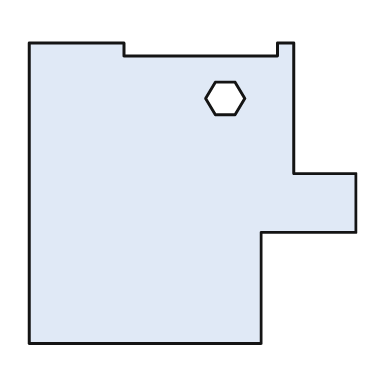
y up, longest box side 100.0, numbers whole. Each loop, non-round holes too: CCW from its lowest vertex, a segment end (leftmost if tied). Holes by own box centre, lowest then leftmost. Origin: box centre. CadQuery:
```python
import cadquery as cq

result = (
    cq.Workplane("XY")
    .moveTo(-50.0, -46.0)
    .lineTo(21.0, -46.0)
    .lineTo(21.0, -12.0)
    .lineTo(50.0, -12.0)
    .lineTo(50.0, 6.0)
    .lineTo(31.0, 6.0)
    .lineTo(31.0, 46.0)
    .lineTo(26.0, 46.0)
    .lineTo(26.0, 42.0)
    .lineTo(-21.0, 42.0)
    .lineTo(-21.0, 46.0)
    .lineTo(-50.0, 46.0)
    .close()
    .moveTo(7.0, 24.0)
    .lineTo(13.0, 24.0)
    .lineTo(16.0, 29.0)
    .lineTo(13.0, 34.0)
    .lineTo(7.0, 34.0)
    .lineTo(4.0, 29.0)
    .close()
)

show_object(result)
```